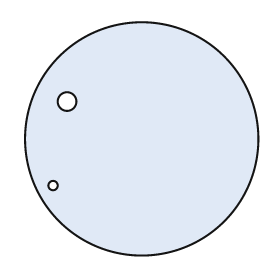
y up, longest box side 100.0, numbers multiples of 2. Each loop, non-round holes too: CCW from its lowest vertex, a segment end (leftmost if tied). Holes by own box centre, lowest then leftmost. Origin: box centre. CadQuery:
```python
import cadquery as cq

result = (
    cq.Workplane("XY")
    .moveTo(0.0, 0.0)
    .circle(50.0)
    .moveTo(-38.0, -20.0)
    .circle(2.0)
    .moveTo(-32.0, 16.0)
    .circle(4.0)
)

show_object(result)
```